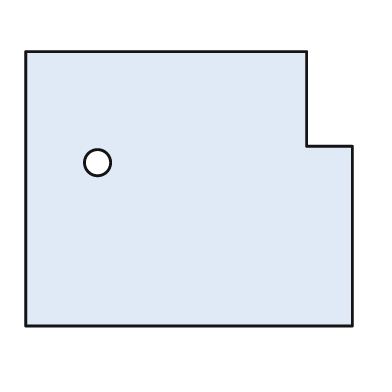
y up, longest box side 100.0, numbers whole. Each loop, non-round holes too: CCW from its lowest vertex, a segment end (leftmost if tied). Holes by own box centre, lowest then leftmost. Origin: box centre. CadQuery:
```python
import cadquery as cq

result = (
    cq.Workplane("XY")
    .moveTo(-50.0, -42.0)
    .lineTo(50.0, -42.0)
    .lineTo(50.0, 13.0)
    .lineTo(36.0, 13.0)
    .lineTo(36.0, 42.0)
    .lineTo(-50.0, 42.0)
    .close()
    .moveTo(-28.0, 8.0)
    .circle(4.0)
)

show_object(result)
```